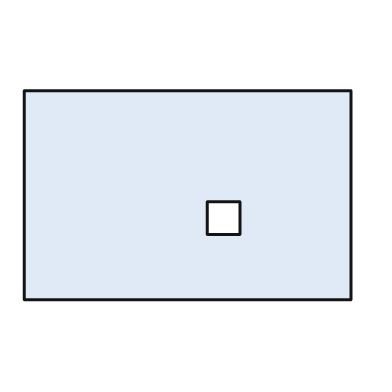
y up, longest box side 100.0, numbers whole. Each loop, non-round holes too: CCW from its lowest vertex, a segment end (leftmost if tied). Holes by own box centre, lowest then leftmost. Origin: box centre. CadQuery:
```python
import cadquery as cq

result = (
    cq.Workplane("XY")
    .moveTo(-50.0, -32.0)
    .lineTo(50.0, -32.0)
    .lineTo(50.0, 32.0)
    .lineTo(-50.0, 32.0)
    .close()
    .moveTo(6.0, -12.0)
    .lineTo(16.0, -12.0)
    .lineTo(16.0, -2.0)
    .lineTo(6.0, -2.0)
    .close()
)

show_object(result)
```